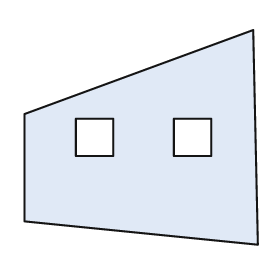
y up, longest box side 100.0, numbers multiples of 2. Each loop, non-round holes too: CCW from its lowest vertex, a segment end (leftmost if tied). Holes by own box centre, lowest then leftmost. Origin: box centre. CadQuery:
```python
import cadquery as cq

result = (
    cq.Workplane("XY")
    .moveTo(50.0, -46.0)
    .lineTo(48.0, 46.0)
    .lineTo(-50.0, 10.0)
    .lineTo(-50.0, -36.0)
    .close()
    .moveTo(-28.0, -8.0)
    .lineTo(-12.0, -8.0)
    .lineTo(-12.0, 8.0)
    .lineTo(-28.0, 8.0)
    .close()
    .moveTo(14.0, -8.0)
    .lineTo(30.0, -8.0)
    .lineTo(30.0, 8.0)
    .lineTo(14.0, 8.0)
    .close()
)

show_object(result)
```